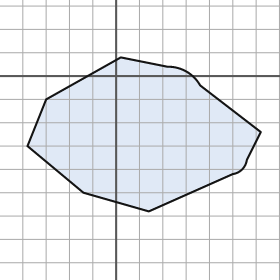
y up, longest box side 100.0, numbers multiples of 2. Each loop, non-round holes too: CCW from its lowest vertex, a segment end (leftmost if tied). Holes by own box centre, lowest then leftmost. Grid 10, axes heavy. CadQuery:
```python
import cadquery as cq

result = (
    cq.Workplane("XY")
    .moveTo(14.0, -58.0)
    .lineTo(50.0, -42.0)
    .threePointArc((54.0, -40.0), (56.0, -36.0))
    .lineTo(62.0, -24.0)
    .lineTo(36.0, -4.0)
    .threePointArc((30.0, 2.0), (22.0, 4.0))
    .lineTo(2.0, 8.0)
    .lineTo(-30.0, -10.0)
    .lineTo(-38.0, -30.0)
    .lineTo(-14.0, -50.0)
    .close()
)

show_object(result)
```